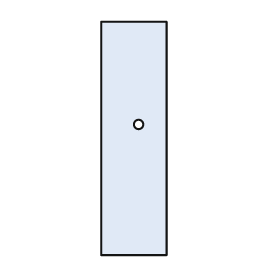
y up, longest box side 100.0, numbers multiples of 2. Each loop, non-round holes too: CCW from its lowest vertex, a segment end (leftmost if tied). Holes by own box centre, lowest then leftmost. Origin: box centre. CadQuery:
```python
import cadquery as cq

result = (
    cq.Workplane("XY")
    .moveTo(-14.0, -50.0)
    .lineTo(14.0, -50.0)
    .lineTo(14.0, 50.0)
    .lineTo(-14.0, 50.0)
    .close()
    .moveTo(2.0, 6.0)
    .circle(2.0)
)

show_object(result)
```